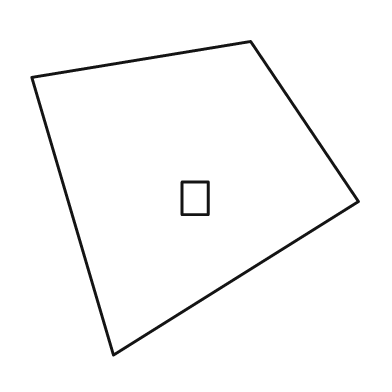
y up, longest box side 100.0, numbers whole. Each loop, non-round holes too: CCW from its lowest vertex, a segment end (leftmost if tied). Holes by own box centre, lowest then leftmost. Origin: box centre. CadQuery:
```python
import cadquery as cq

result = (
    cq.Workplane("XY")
    .moveTo(-25.0, -48.0)
    .lineTo(50.0, -1.0)
    .lineTo(17.0, 48.0)
    .lineTo(-50.0, 37.0)
    .close()
    .moveTo(-4.0, -5.0)
    .lineTo(4.0, -5.0)
    .lineTo(4.0, 5.0)
    .lineTo(-4.0, 5.0)
    .close()
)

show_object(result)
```